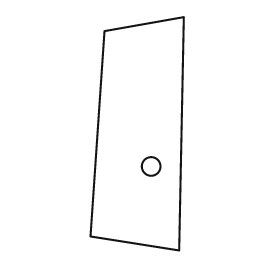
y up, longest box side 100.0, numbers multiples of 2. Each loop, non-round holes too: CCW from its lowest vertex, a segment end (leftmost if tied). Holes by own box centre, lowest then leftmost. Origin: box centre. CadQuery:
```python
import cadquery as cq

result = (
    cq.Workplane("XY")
    .moveTo(18.0, -50.0)
    .lineTo(20.0, 50.0)
    .lineTo(-14.0, 44.0)
    .lineTo(-20.0, -44.0)
    .close()
    .moveTo(6.0, -14.0)
    .circle(4.0)
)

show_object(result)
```